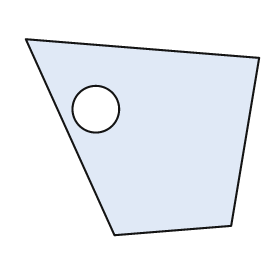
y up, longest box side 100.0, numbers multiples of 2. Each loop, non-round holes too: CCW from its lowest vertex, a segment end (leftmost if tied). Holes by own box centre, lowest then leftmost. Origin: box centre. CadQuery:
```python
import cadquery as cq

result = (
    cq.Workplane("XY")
    .moveTo(-12.0, -42.0)
    .lineTo(38.0, -38.0)
    .lineTo(50.0, 34.0)
    .lineTo(-50.0, 42.0)
    .close()
    .moveTo(-20.0, 12.0)
    .circle(10.0)
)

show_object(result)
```